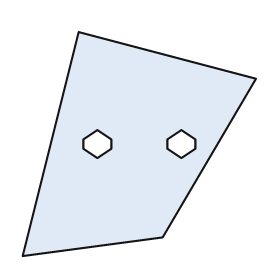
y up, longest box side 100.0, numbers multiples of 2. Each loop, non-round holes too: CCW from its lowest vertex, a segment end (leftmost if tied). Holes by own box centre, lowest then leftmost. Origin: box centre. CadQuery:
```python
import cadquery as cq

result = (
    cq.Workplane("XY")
    .moveTo(-50.0, -48.0)
    .lineTo(10.0, -40.0)
    .lineTo(50.0, 28.0)
    .lineTo(-26.0, 48.0)
    .close()
    .moveTo(-18.0, -6.0)
    .lineTo(-12.0, -2.0)
    .lineTo(-12.0, 2.0)
    .lineTo(-18.0, 6.0)
    .lineTo(-24.0, 2.0)
    .lineTo(-24.0, -2.0)
    .close()
    .moveTo(18.0, -6.0)
    .lineTo(24.0, -2.0)
    .lineTo(24.0, 2.0)
    .lineTo(18.0, 6.0)
    .lineTo(12.0, 2.0)
    .lineTo(12.0, -2.0)
    .close()
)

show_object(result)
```